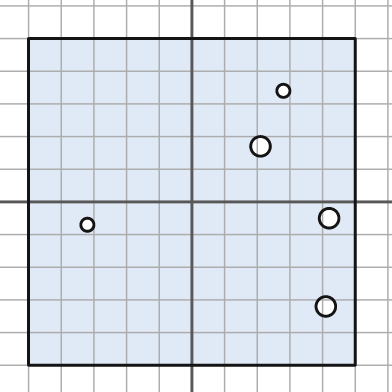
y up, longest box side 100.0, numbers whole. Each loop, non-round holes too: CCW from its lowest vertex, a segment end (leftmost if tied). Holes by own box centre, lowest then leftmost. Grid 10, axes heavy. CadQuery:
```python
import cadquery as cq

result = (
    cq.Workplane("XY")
    .moveTo(-50.0, -50.0)
    .lineTo(50.0, -50.0)
    .lineTo(50.0, 50.0)
    .lineTo(-50.0, 50.0)
    .close()
    .moveTo(41.0, -32.0)
    .circle(3.0)
    .moveTo(-32.0, -7.0)
    .circle(2.0)
    .moveTo(42.0, -5.0)
    .circle(3.0)
    .moveTo(21.0, 17.0)
    .circle(3.0)
    .moveTo(28.0, 34.0)
    .circle(2.0)
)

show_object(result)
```